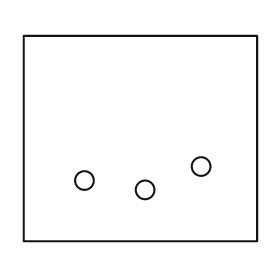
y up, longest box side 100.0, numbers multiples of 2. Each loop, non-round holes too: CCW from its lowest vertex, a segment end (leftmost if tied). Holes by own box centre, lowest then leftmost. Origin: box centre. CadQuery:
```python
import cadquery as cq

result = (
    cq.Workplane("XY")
    .moveTo(-50.0, -44.0)
    .lineTo(50.0, -44.0)
    .lineTo(50.0, 44.0)
    .lineTo(-50.0, 44.0)
    .close()
    .moveTo(2.0, -22.0)
    .circle(4.0)
    .moveTo(-24.0, -18.0)
    .circle(4.0)
    .moveTo(26.0, -12.0)
    .circle(4.0)
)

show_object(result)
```